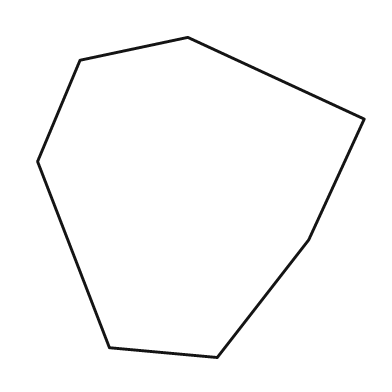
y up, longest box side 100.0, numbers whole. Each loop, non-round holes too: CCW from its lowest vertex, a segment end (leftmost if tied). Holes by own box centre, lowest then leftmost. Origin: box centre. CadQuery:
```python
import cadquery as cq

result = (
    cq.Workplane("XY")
    .moveTo(5.0, -49.0)
    .lineTo(33.0, -13.0)
    .lineTo(50.0, 24.0)
    .lineTo(-4.0, 49.0)
    .lineTo(-37.0, 42.0)
    .lineTo(-50.0, 11.0)
    .lineTo(-28.0, -46.0)
    .close()
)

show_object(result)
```